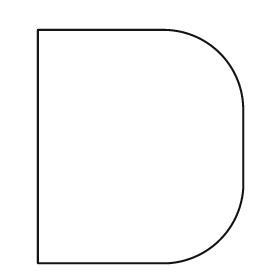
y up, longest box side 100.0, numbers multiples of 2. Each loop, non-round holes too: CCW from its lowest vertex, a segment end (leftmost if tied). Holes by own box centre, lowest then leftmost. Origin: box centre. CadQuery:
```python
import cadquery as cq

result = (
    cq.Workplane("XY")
    .moveTo(-44.0, -50.0)
    .lineTo(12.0, -50.0)
    .threePointArc((34.0, -40.0), (44.0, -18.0))
    .lineTo(44.0, 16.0)
    .threePointArc((34.0, 40.0), (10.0, 50.0))
    .lineTo(-44.0, 50.0)
    .close()
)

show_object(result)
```